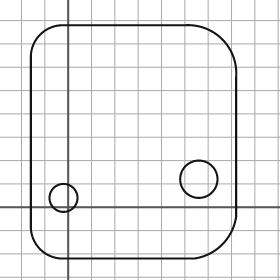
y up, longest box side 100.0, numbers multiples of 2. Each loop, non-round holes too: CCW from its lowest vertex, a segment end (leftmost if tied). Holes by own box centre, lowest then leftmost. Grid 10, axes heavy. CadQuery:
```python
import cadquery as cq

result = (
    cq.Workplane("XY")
    .moveTo(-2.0, -22.0)
    .lineTo(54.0, -22.0)
    .threePointArc((66.0, -16.0), (72.0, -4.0))
    .lineTo(72.0, 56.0)
    .threePointArc((66.0, 72.0), (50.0, 78.0))
    .lineTo(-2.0, 78.0)
    .threePointArc((-12.0, 74.0), (-16.0, 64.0))
    .lineTo(-16.0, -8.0)
    .threePointArc((-12.0, -18.0), (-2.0, -22.0))
    .close()
    .moveTo(-2.0, 4.0)
    .circle(6.0)
    .moveTo(56.0, 12.0)
    .circle(8.0)
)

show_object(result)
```